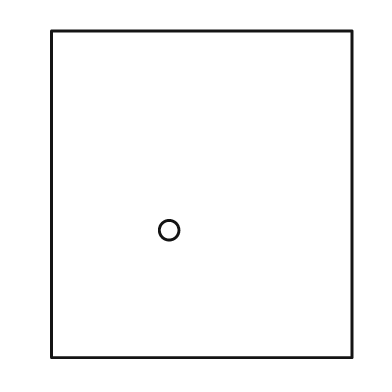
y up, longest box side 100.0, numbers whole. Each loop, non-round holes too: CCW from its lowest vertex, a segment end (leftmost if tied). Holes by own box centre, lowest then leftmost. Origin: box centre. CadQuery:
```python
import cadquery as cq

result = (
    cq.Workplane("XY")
    .moveTo(-46.0, -50.0)
    .lineTo(46.0, -50.0)
    .lineTo(46.0, 50.0)
    .lineTo(-46.0, 50.0)
    .close()
    .moveTo(-10.0, -11.0)
    .circle(3.0)
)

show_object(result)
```